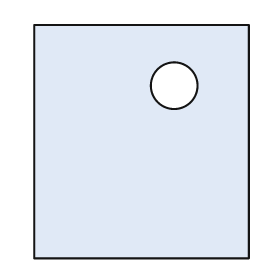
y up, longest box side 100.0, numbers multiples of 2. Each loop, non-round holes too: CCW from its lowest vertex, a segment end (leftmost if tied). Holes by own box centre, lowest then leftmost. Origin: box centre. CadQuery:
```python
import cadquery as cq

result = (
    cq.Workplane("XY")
    .moveTo(-46.0, -50.0)
    .lineTo(46.0, -50.0)
    .lineTo(46.0, 50.0)
    .lineTo(-46.0, 50.0)
    .close()
    .moveTo(14.0, 24.0)
    .circle(10.0)
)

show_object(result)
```